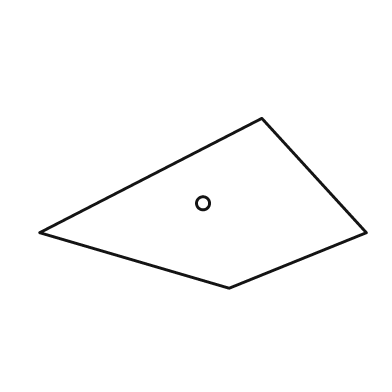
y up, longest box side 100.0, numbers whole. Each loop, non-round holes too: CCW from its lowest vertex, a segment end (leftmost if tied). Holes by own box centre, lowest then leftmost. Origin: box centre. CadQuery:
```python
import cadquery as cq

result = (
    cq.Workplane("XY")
    .moveTo(8.0, -26.0)
    .lineTo(50.0, -9.0)
    .lineTo(18.0, 26.0)
    .lineTo(-50.0, -9.0)
    .close()
    .moveTo(0.0, 0.0)
    .circle(2.0)
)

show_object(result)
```